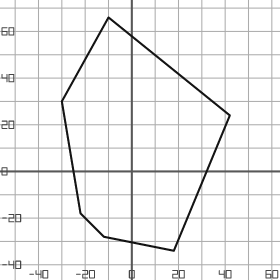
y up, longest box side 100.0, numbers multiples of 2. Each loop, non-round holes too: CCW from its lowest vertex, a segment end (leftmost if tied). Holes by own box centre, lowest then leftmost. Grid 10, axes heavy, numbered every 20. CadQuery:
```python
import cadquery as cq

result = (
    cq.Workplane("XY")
    .moveTo(18.0, -34.0)
    .lineTo(42.0, 24.0)
    .lineTo(-10.0, 66.0)
    .lineTo(-30.0, 30.0)
    .lineTo(-22.0, -18.0)
    .lineTo(-12.0, -28.0)
    .close()
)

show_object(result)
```